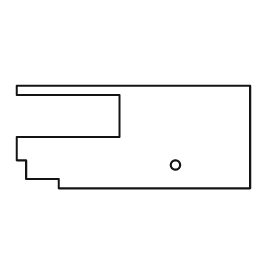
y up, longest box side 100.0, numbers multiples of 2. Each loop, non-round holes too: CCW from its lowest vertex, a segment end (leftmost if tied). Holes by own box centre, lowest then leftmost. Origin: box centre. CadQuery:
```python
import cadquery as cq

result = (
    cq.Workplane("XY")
    .moveTo(-32.0, -22.0)
    .lineTo(50.0, -22.0)
    .lineTo(50.0, 22.0)
    .lineTo(-50.0, 22.0)
    .lineTo(-50.0, 18.0)
    .lineTo(-6.0, 18.0)
    .lineTo(-6.0, 0.0)
    .lineTo(-50.0, 0.0)
    .lineTo(-50.0, -10.0)
    .lineTo(-46.0, -10.0)
    .lineTo(-46.0, -18.0)
    .lineTo(-32.0, -18.0)
    .close()
    .moveTo(18.0, -12.0)
    .circle(2.0)
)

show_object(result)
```